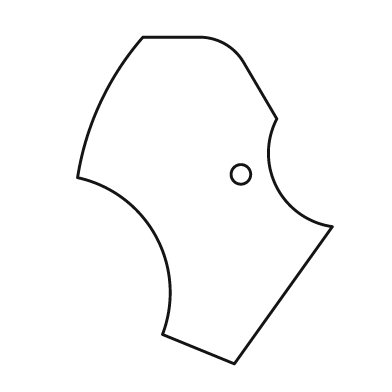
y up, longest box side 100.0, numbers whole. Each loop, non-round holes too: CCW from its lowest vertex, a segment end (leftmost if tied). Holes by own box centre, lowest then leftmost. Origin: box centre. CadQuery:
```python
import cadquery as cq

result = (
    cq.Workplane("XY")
    .moveTo(9.0, -50.0)
    .lineTo(39.0, -8.0)
    .threePointArc((22.0, 4.0), (22.0, 25.0))
    .lineTo(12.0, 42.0)
    .threePointArc((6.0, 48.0), (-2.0, 50.0))
    .lineTo(-19.0, 50.0)
    .threePointArc((-32.0, 30.0), (-39.0, 7.0))
    .threePointArc((-15.0, -11.0), (-13.0, -41.0))
    .close()
    .moveTo(11.0, 8.0)
    .circle(3.0)
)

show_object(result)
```